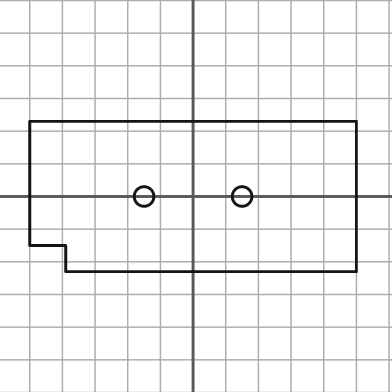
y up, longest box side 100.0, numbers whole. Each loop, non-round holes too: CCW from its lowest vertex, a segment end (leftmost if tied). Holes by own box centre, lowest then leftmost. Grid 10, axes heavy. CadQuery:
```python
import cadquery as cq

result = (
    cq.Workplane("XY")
    .moveTo(-39.0, -23.0)
    .lineTo(50.0, -23.0)
    .lineTo(50.0, 23.0)
    .lineTo(-50.0, 23.0)
    .lineTo(-50.0, -15.0)
    .lineTo(-39.0, -15.0)
    .close()
    .moveTo(-15.0, 0.0)
    .circle(3.0)
    .moveTo(15.0, 0.0)
    .circle(3.0)
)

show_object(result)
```